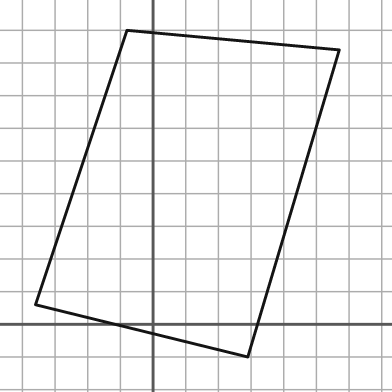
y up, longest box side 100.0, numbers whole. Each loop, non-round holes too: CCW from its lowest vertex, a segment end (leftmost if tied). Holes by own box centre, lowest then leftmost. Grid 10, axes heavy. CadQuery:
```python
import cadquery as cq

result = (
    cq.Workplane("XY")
    .moveTo(29.0, -10.0)
    .lineTo(57.0, 84.0)
    .lineTo(-8.0, 90.0)
    .lineTo(-36.0, 6.0)
    .close()
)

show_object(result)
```